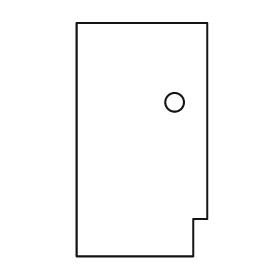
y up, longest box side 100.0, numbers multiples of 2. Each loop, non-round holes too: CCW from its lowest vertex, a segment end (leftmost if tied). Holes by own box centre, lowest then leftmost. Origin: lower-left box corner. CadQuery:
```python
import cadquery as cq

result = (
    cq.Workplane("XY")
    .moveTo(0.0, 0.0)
    .lineTo(50.0, 0.0)
    .lineTo(50.0, 16.0)
    .lineTo(56.0, 16.0)
    .lineTo(56.0, 100.0)
    .lineTo(0.0, 100.0)
    .close()
    .moveTo(42.0, 66.0)
    .circle(4.0)
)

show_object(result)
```